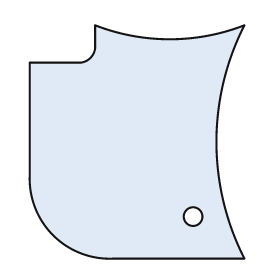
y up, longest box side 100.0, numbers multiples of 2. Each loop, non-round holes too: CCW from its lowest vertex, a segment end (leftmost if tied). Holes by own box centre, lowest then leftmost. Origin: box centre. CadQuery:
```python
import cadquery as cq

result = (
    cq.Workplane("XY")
    .moveTo(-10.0, -50.0)
    .lineTo(46.0, -50.0)
    .threePointArc((34.0, 0.0), (46.0, 50.0))
    .threePointArc((14.0, 44.0), (-18.0, 50.0))
    .lineTo(-18.0, 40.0)
    .threePointArc((-20.0, 36.0), (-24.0, 34.0))
    .lineTo(-46.0, 34.0)
    .lineTo(-46.0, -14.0)
    .threePointArc((-36.0, -40.0), (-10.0, -50.0))
    .close()
    .moveTo(24.0, -32.0)
    .circle(4.0)
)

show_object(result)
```